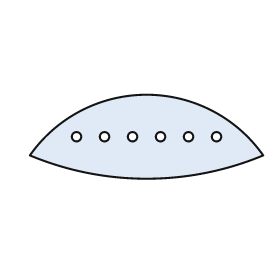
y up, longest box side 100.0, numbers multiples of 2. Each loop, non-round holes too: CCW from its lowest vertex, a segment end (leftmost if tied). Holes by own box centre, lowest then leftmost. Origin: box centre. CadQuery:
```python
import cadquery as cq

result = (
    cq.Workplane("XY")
    .moveTo(-50.0, -8.0)
    .threePointArc((0.0, -18.0), (50.0, -8.0))
    .threePointArc((0.0, 18.0), (-50.0, -8.0))
    .close()
    .moveTo(-30.0, 0.0)
    .circle(2.0)
    .moveTo(-18.0, 0.0)
    .circle(2.0)
    .moveTo(-6.0, 0.0)
    .circle(2.0)
    .moveTo(6.0, 0.0)
    .circle(2.0)
    .moveTo(18.0, 0.0)
    .circle(2.0)
    .moveTo(30.0, 0.0)
    .circle(2.0)
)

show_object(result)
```